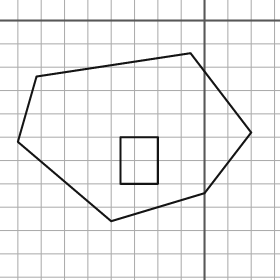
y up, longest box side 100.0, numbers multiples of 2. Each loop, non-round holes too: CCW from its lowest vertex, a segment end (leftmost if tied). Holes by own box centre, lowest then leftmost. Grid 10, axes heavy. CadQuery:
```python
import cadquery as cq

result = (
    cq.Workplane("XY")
    .moveTo(-40.0, -86.0)
    .lineTo(0.0, -74.0)
    .lineTo(20.0, -48.0)
    .lineTo(-6.0, -14.0)
    .lineTo(-72.0, -24.0)
    .lineTo(-80.0, -52.0)
    .close()
    .moveTo(-36.0, -70.0)
    .lineTo(-20.0, -70.0)
    .lineTo(-20.0, -50.0)
    .lineTo(-36.0, -50.0)
    .close()
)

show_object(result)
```